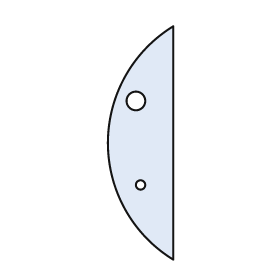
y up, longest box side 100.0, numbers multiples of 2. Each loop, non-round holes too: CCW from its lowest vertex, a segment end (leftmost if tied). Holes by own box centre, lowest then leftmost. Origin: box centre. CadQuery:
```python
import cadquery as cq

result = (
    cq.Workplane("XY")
    .moveTo(14.0, -50.0)
    .lineTo(14.0, 50.0)
    .threePointArc((-14.0, 0.0), (14.0, -50.0))
    .close()
    .moveTo(0.0, -18.0)
    .circle(2.0)
    .moveTo(-2.0, 18.0)
    .circle(4.0)
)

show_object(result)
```